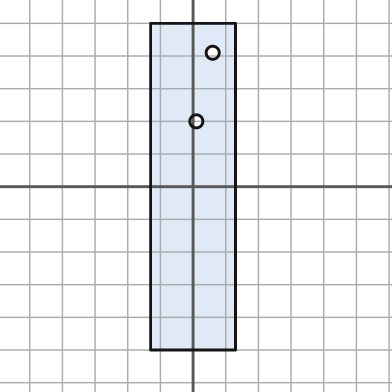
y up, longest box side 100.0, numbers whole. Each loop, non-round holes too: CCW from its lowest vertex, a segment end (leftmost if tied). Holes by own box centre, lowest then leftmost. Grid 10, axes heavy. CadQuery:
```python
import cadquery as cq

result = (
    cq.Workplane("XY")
    .moveTo(-13.0, -50.0)
    .lineTo(13.0, -50.0)
    .lineTo(13.0, 50.0)
    .lineTo(-13.0, 50.0)
    .close()
    .moveTo(1.0, 20.0)
    .circle(2.0)
    .moveTo(6.0, 41.0)
    .circle(2.0)
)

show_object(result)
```